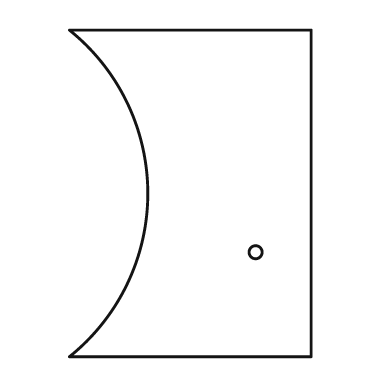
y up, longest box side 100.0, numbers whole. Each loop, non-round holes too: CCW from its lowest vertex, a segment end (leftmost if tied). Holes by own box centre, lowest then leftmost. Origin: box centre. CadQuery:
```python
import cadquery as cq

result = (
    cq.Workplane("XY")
    .moveTo(-37.0, -50.0)
    .lineTo(37.0, -50.0)
    .lineTo(37.0, 50.0)
    .lineTo(-37.0, 50.0)
    .threePointArc((-13.0, 0.0), (-37.0, -50.0))
    .close()
    .moveTo(20.0, -18.0)
    .circle(2.0)
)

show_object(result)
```